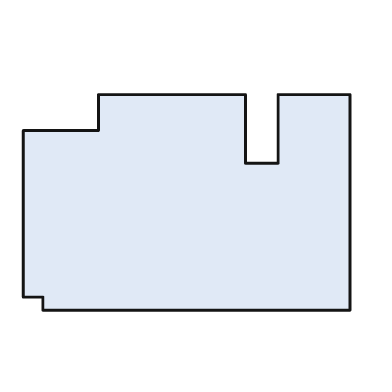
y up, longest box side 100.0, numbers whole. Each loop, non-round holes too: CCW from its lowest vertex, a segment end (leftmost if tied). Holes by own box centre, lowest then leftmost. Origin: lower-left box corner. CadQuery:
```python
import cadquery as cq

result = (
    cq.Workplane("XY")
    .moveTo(6.0, 0.0)
    .lineTo(100.0, 0.0)
    .lineTo(100.0, 66.0)
    .lineTo(78.0, 66.0)
    .lineTo(78.0, 45.0)
    .lineTo(68.0, 45.0)
    .lineTo(68.0, 66.0)
    .lineTo(23.0, 66.0)
    .lineTo(23.0, 55.0)
    .lineTo(0.0, 55.0)
    .lineTo(0.0, 4.0)
    .lineTo(6.0, 4.0)
    .close()
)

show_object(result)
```